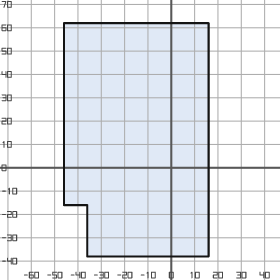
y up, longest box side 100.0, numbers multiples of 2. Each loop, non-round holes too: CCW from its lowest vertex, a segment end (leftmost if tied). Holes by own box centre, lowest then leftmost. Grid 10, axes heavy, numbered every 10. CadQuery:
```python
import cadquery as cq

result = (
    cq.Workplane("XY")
    .moveTo(-36.0, -38.0)
    .lineTo(16.0, -38.0)
    .lineTo(16.0, 62.0)
    .lineTo(-46.0, 62.0)
    .lineTo(-46.0, -16.0)
    .lineTo(-36.0, -16.0)
    .close()
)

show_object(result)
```